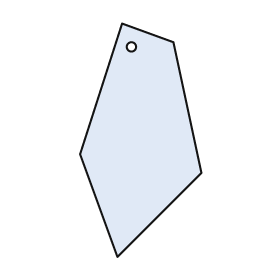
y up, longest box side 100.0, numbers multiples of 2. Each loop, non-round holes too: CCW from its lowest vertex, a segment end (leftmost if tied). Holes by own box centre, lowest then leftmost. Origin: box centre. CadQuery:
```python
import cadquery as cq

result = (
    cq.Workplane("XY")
    .moveTo(-10.0, -50.0)
    .lineTo(26.0, -14.0)
    .lineTo(14.0, 42.0)
    .lineTo(-8.0, 50.0)
    .lineTo(-26.0, -6.0)
    .close()
    .moveTo(-4.0, 40.0)
    .circle(2.0)
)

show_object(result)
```